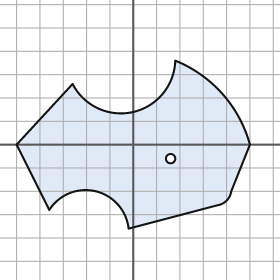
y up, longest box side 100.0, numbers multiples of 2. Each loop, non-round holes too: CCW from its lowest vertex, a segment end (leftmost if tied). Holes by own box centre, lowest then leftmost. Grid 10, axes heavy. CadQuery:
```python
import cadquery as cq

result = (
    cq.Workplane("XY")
    .moveTo(-2.0, -36.0)
    .lineTo(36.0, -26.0)
    .threePointArc((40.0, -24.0), (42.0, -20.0))
    .lineTo(50.0, 0.0)
    .threePointArc((38.0, 22.0), (18.0, 36.0))
    .threePointArc((0.0, 14.0), (-26.0, 26.0))
    .lineTo(-50.0, 0.0)
    .lineTo(-36.0, -28.0)
    .threePointArc((-16.0, -20.0), (-2.0, -36.0))
    .close()
    .moveTo(16.0, -6.0)
    .circle(2.0)
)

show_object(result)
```